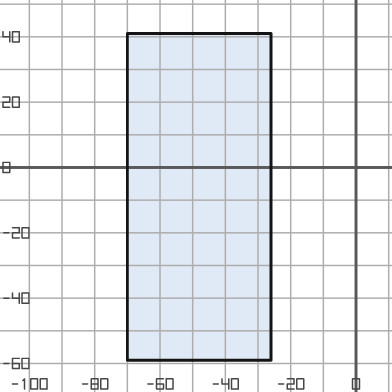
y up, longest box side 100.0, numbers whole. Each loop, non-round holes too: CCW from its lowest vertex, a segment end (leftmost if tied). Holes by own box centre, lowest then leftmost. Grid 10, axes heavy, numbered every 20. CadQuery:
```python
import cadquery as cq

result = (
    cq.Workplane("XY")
    .moveTo(-70.0, -59.0)
    .lineTo(-26.0, -59.0)
    .lineTo(-26.0, 41.0)
    .lineTo(-70.0, 41.0)
    .close()
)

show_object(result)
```